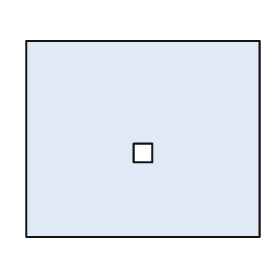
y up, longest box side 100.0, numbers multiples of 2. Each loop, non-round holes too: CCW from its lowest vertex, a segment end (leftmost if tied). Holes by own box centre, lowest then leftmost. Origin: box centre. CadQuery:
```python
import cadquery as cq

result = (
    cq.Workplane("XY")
    .moveTo(-50.0, -42.0)
    .lineTo(50.0, -42.0)
    .lineTo(50.0, 42.0)
    .lineTo(-50.0, 42.0)
    .close()
    .moveTo(-4.0, -10.0)
    .lineTo(4.0, -10.0)
    .lineTo(4.0, -2.0)
    .lineTo(-4.0, -2.0)
    .close()
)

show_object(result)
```